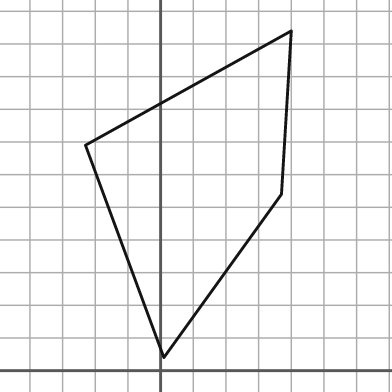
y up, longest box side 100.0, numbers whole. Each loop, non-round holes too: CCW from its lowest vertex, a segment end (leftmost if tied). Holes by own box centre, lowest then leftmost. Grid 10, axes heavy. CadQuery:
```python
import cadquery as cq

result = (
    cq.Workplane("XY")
    .moveTo(1.0, 4.0)
    .lineTo(37.0, 54.0)
    .lineTo(40.0, 104.0)
    .lineTo(-23.0, 69.0)
    .close()
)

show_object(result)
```